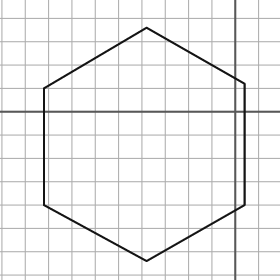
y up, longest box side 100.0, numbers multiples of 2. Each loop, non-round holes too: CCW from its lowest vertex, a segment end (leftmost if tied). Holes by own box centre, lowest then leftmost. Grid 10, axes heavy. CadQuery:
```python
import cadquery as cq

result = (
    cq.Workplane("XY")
    .moveTo(-38.0, -64.0)
    .lineTo(4.0, -40.0)
    .lineTo(4.0, 12.0)
    .lineTo(-38.0, 36.0)
    .lineTo(-82.0, 10.0)
    .lineTo(-82.0, -40.0)
    .close()
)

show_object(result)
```